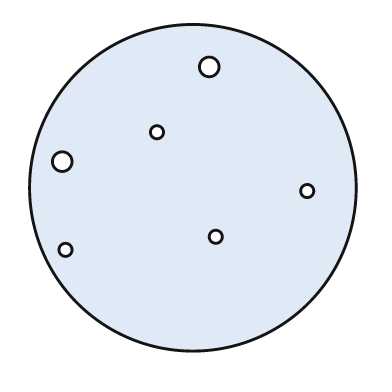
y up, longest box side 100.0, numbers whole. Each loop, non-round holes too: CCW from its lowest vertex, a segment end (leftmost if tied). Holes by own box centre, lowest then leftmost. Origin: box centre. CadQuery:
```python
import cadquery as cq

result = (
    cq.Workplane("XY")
    .moveTo(0.0, 0.0)
    .circle(50.0)
    .moveTo(-39.0, -19.0)
    .circle(2.0)
    .moveTo(7.0, -15.0)
    .circle(2.0)
    .moveTo(35.0, -1.0)
    .circle(2.0)
    .moveTo(-40.0, 8.0)
    .circle(3.0)
    .moveTo(-11.0, 17.0)
    .circle(2.0)
    .moveTo(5.0, 37.0)
    .circle(3.0)
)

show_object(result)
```